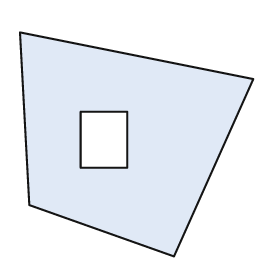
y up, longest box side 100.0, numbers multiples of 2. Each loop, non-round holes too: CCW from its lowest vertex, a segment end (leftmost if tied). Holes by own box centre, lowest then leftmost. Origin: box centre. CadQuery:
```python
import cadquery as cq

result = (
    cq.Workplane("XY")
    .moveTo(16.0, -48.0)
    .lineTo(50.0, 28.0)
    .lineTo(-50.0, 48.0)
    .lineTo(-46.0, -26.0)
    .close()
    .moveTo(-24.0, -10.0)
    .lineTo(-4.0, -10.0)
    .lineTo(-4.0, 14.0)
    .lineTo(-24.0, 14.0)
    .close()
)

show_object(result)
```